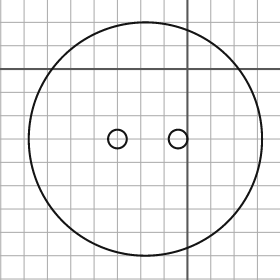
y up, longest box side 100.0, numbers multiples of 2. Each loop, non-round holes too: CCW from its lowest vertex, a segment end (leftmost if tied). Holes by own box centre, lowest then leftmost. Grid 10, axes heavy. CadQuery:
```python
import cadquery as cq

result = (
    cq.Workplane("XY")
    .moveTo(-18.0, -30.0)
    .circle(50.0)
    .moveTo(-30.0, -30.0)
    .circle(4.0)
    .moveTo(-4.0, -30.0)
    .circle(4.0)
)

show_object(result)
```